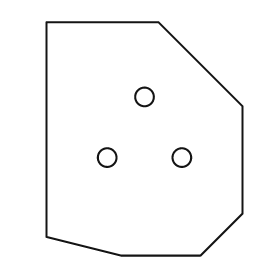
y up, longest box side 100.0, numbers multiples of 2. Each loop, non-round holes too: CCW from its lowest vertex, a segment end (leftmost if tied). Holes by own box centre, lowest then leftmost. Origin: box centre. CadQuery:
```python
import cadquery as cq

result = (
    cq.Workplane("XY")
    .moveTo(-10.0, -50.0)
    .lineTo(24.0, -50.0)
    .lineTo(42.0, -32.0)
    .lineTo(42.0, 14.0)
    .lineTo(6.0, 50.0)
    .lineTo(-42.0, 50.0)
    .lineTo(-42.0, -42.0)
    .close()
    .moveTo(-16.0, -8.0)
    .circle(4.0)
    .moveTo(16.0, -8.0)
    .circle(4.0)
    .moveTo(0.0, 18.0)
    .circle(4.0)
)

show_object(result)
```